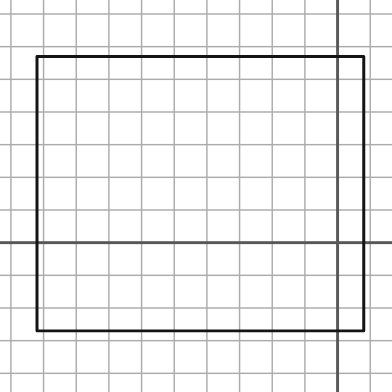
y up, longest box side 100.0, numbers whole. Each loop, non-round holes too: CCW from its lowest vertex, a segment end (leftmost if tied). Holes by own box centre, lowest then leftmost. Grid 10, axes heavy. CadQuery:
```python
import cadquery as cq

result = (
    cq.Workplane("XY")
    .moveTo(-92.0, -27.0)
    .lineTo(8.0, -27.0)
    .lineTo(8.0, 57.0)
    .lineTo(-92.0, 57.0)
    .close()
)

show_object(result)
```